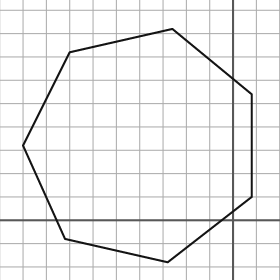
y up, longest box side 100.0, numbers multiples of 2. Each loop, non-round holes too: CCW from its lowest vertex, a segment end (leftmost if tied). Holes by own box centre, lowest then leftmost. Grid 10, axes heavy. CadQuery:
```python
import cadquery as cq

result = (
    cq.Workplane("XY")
    .moveTo(-28.0, -18.0)
    .lineTo(8.0, 10.0)
    .lineTo(8.0, 54.0)
    .lineTo(-26.0, 82.0)
    .lineTo(-70.0, 72.0)
    .lineTo(-90.0, 32.0)
    .lineTo(-72.0, -8.0)
    .close()
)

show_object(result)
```